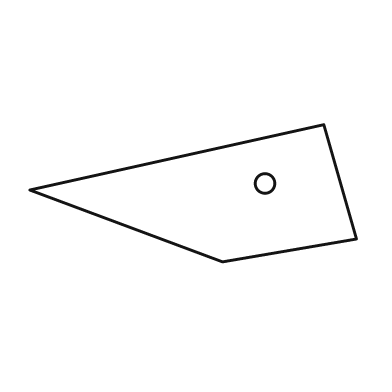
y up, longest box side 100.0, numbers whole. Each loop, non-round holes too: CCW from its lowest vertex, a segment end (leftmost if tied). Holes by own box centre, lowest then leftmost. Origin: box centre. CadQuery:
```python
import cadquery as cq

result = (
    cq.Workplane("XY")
    .moveTo(9.0, -21.0)
    .lineTo(50.0, -14.0)
    .lineTo(40.0, 21.0)
    .lineTo(-50.0, 1.0)
    .close()
    .moveTo(22.0, 3.0)
    .circle(3.0)
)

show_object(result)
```